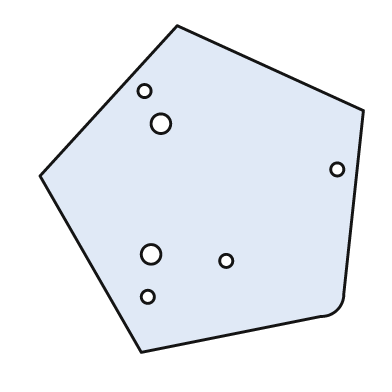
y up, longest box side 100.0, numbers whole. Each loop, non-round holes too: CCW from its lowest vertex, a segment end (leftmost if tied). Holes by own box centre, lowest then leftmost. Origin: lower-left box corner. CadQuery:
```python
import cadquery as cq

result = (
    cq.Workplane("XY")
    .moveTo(31.0, 0.0)
    .lineTo(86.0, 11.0)
    .threePointArc((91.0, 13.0), (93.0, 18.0))
    .lineTo(99.0, 74.0)
    .lineTo(42.0, 100.0)
    .lineTo(0.0, 54.0)
    .close()
    .moveTo(33.0, 17.0)
    .circle(2.0)
    .moveTo(57.0, 28.0)
    .circle(2.0)
    .moveTo(34.0, 30.0)
    .circle(3.0)
    .moveTo(91.0, 56.0)
    .circle(2.0)
    .moveTo(37.0, 70.0)
    .circle(3.0)
    .moveTo(32.0, 80.0)
    .circle(2.0)
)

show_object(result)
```